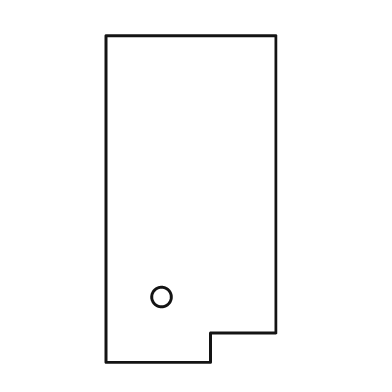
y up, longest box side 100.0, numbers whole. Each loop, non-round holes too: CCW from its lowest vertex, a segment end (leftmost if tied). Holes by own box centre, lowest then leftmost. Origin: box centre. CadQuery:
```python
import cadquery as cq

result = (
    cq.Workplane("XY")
    .moveTo(-26.0, -50.0)
    .lineTo(6.0, -50.0)
    .lineTo(6.0, -41.0)
    .lineTo(26.0, -41.0)
    .lineTo(26.0, 50.0)
    .lineTo(-26.0, 50.0)
    .close()
    .moveTo(-9.0, -30.0)
    .circle(3.0)
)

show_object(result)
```